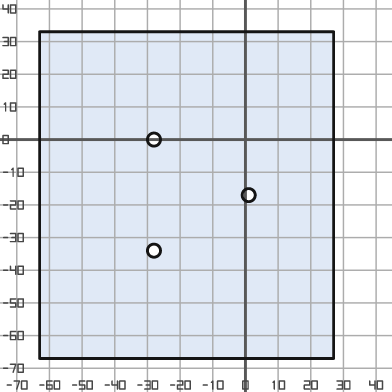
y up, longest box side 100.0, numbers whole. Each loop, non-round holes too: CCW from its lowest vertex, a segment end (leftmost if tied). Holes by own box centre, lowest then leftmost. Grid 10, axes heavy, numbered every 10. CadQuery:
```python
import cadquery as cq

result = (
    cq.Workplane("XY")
    .moveTo(-63.0, -67.0)
    .lineTo(27.0, -67.0)
    .lineTo(27.0, 33.0)
    .lineTo(-63.0, 33.0)
    .close()
    .moveTo(-28.0, -34.0)
    .circle(2.0)
    .moveTo(1.0, -17.0)
    .circle(2.0)
    .moveTo(-28.0, 0.0)
    .circle(2.0)
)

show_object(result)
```